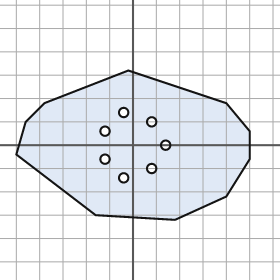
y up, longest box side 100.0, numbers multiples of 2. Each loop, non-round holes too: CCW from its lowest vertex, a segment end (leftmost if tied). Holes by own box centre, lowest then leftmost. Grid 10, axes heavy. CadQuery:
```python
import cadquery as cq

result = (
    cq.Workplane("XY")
    .moveTo(18.0, -32.0)
    .lineTo(40.0, -22.0)
    .lineTo(50.0, -6.0)
    .lineTo(50.0, 6.0)
    .lineTo(40.0, 18.0)
    .lineTo(-2.0, 32.0)
    .lineTo(-38.0, 18.0)
    .lineTo(-46.0, 10.0)
    .lineTo(-50.0, -4.0)
    .lineTo(-16.0, -30.0)
    .close()
    .moveTo(-4.0, -14.0)
    .circle(2.0)
    .moveTo(8.0, -10.0)
    .circle(2.0)
    .moveTo(-12.0, -6.0)
    .circle(2.0)
    .moveTo(14.0, 0.0)
    .circle(2.0)
    .moveTo(-12.0, 6.0)
    .circle(2.0)
    .moveTo(8.0, 10.0)
    .circle(2.0)
    .moveTo(-4.0, 14.0)
    .circle(2.0)
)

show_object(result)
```